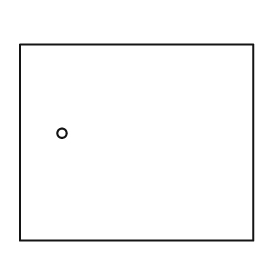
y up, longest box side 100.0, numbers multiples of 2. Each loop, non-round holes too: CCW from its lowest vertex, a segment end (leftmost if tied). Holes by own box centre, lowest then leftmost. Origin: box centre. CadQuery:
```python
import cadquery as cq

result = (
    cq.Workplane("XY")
    .moveTo(-50.0, -42.0)
    .lineTo(50.0, -42.0)
    .lineTo(50.0, 42.0)
    .lineTo(-50.0, 42.0)
    .close()
    .moveTo(-32.0, 4.0)
    .circle(2.0)
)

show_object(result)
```